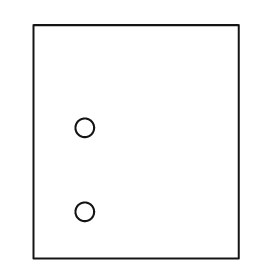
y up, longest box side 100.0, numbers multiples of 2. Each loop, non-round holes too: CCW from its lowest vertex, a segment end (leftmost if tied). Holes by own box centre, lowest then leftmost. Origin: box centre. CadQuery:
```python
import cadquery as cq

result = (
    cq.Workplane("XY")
    .moveTo(-44.0, -50.0)
    .lineTo(44.0, -50.0)
    .lineTo(44.0, 50.0)
    .lineTo(-44.0, 50.0)
    .close()
    .moveTo(-22.0, -30.0)
    .circle(4.0)
    .moveTo(-22.0, 6.0)
    .circle(4.0)
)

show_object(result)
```